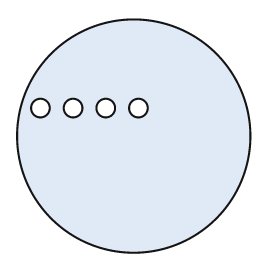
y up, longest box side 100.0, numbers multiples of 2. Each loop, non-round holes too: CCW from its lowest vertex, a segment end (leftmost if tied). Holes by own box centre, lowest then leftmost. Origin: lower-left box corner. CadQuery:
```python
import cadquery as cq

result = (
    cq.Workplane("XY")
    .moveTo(50.0, 50.0)
    .circle(50.0)
    .moveTo(10.0, 62.0)
    .circle(4.0)
    .moveTo(24.0, 62.0)
    .circle(4.0)
    .moveTo(38.0, 62.0)
    .circle(4.0)
    .moveTo(52.0, 62.0)
    .circle(4.0)
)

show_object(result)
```